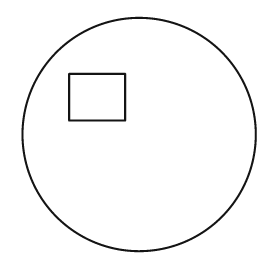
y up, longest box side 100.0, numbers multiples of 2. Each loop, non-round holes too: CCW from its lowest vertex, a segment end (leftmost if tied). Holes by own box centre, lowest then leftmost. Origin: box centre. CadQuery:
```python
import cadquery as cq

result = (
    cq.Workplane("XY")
    .moveTo(0.0, 0.0)
    .circle(50.0)
    .moveTo(-30.0, 6.0)
    .lineTo(-6.0, 6.0)
    .lineTo(-6.0, 26.0)
    .lineTo(-30.0, 26.0)
    .close()
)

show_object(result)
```